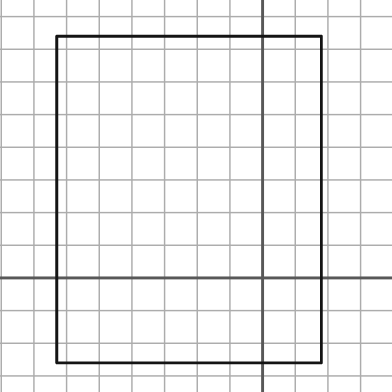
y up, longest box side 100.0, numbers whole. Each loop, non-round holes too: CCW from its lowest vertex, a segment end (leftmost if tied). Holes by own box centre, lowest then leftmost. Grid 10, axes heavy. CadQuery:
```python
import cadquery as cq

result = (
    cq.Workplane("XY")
    .moveTo(-63.0, -26.0)
    .lineTo(18.0, -26.0)
    .lineTo(18.0, 74.0)
    .lineTo(-63.0, 74.0)
    .close()
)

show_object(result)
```